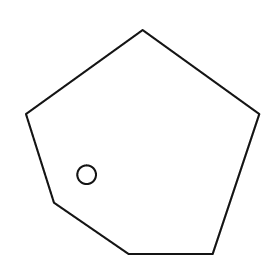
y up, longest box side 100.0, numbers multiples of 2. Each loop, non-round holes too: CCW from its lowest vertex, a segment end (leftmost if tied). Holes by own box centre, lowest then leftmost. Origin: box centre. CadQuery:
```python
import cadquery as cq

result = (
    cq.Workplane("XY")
    .moveTo(-6.0, -48.0)
    .lineTo(30.0, -48.0)
    .lineTo(50.0, 12.0)
    .lineTo(0.0, 48.0)
    .lineTo(-50.0, 12.0)
    .lineTo(-38.0, -26.0)
    .close()
    .moveTo(-24.0, -14.0)
    .circle(4.0)
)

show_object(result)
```